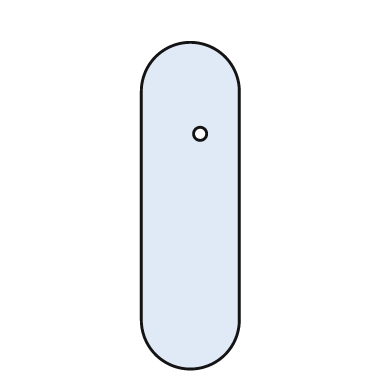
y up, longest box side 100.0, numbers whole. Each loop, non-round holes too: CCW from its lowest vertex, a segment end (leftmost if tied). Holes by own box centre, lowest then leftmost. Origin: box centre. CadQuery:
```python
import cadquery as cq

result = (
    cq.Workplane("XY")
    .moveTo(-15.0, -35.0)
    .threePointArc((0.0, -50.0), (15.0, -35.0))
    .lineTo(15.0, 35.0)
    .threePointArc((0.0, 50.0), (-15.0, 35.0))
    .close()
    .moveTo(3.0, 22.0)
    .circle(2.0)
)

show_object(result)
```